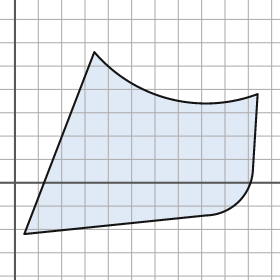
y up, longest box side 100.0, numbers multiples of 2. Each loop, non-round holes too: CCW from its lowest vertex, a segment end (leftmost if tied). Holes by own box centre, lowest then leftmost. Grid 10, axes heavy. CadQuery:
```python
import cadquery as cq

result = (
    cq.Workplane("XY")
    .moveTo(4.0, -22.0)
    .lineTo(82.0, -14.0)
    .threePointArc((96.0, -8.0), (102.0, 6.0))
    .lineTo(104.0, 38.0)
    .threePointArc((66.0, 36.0), (34.0, 56.0))
    .close()
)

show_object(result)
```